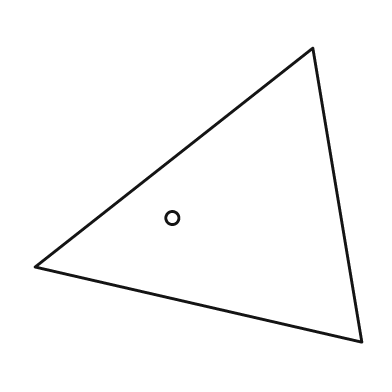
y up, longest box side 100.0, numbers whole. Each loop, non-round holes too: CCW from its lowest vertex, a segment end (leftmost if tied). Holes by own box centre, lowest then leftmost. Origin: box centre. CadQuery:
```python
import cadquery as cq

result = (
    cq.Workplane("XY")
    .moveTo(50.0, -45.0)
    .lineTo(35.0, 45.0)
    .lineTo(-50.0, -22.0)
    .close()
    .moveTo(-8.0, -7.0)
    .circle(2.0)
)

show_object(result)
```